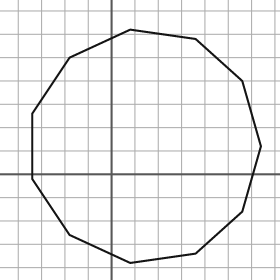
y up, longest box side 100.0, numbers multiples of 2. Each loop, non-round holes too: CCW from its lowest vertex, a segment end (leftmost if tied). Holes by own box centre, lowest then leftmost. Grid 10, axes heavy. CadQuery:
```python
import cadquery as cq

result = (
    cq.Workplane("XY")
    .moveTo(8.0, -38.0)
    .lineTo(36.0, -34.0)
    .lineTo(56.0, -16.0)
    .lineTo(64.0, 12.0)
    .lineTo(56.0, 40.0)
    .lineTo(36.0, 58.0)
    .lineTo(8.0, 62.0)
    .lineTo(-18.0, 50.0)
    .lineTo(-34.0, 26.0)
    .lineTo(-34.0, -2.0)
    .lineTo(-18.0, -26.0)
    .close()
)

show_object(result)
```